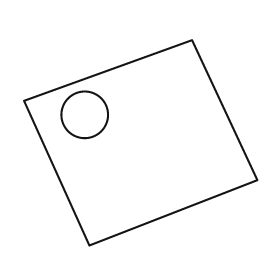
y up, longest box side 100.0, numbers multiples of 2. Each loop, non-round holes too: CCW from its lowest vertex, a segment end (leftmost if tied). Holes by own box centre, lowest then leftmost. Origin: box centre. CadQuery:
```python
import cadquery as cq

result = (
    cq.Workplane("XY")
    .moveTo(-22.0, -44.0)
    .lineTo(50.0, -16.0)
    .lineTo(22.0, 44.0)
    .lineTo(-50.0, 18.0)
    .close()
    .moveTo(-24.0, 12.0)
    .circle(10.0)
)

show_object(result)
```